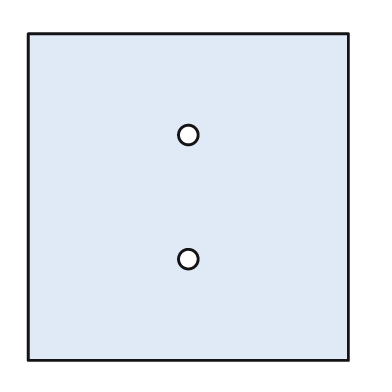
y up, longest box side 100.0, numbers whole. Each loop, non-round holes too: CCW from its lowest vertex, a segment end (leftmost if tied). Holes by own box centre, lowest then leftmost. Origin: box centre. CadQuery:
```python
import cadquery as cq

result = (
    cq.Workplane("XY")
    .moveTo(-49.0, -50.0)
    .lineTo(49.0, -50.0)
    .lineTo(49.0, 50.0)
    .lineTo(-49.0, 50.0)
    .close()
    .moveTo(0.0, -19.0)
    .circle(3.0)
    .moveTo(0.0, 19.0)
    .circle(3.0)
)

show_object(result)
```